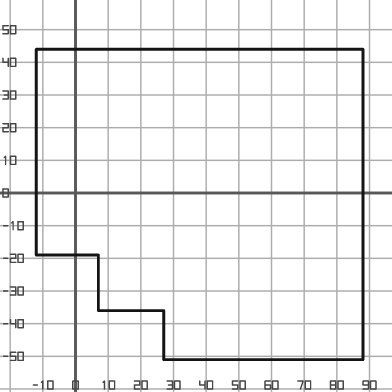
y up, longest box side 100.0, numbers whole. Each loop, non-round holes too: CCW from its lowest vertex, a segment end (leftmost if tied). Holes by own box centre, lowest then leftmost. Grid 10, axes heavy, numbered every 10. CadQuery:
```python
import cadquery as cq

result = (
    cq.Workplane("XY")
    .moveTo(27.0, -51.0)
    .lineTo(88.0, -51.0)
    .lineTo(88.0, 44.0)
    .lineTo(-12.0, 44.0)
    .lineTo(-12.0, -19.0)
    .lineTo(7.0, -19.0)
    .lineTo(7.0, -36.0)
    .lineTo(27.0, -36.0)
    .close()
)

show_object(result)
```